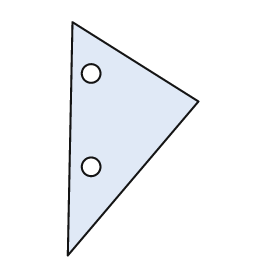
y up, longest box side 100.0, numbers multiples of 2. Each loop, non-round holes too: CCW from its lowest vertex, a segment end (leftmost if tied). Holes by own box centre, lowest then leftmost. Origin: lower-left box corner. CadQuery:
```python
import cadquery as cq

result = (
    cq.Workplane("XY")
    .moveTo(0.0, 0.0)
    .lineTo(56.0, 66.0)
    .lineTo(2.0, 100.0)
    .close()
    .moveTo(10.0, 38.0)
    .circle(4.0)
    .moveTo(10.0, 78.0)
    .circle(4.0)
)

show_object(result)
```